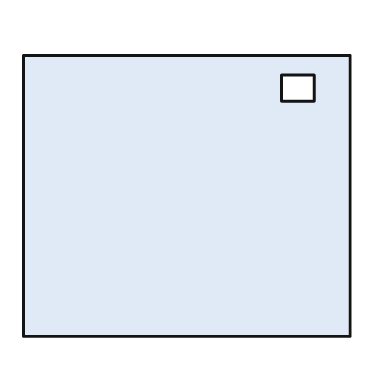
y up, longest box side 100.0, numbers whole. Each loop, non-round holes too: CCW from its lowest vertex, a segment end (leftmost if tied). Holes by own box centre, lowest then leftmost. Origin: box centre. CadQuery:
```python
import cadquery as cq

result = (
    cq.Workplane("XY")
    .moveTo(-50.0, -43.0)
    .lineTo(50.0, -43.0)
    .lineTo(50.0, 43.0)
    .lineTo(-50.0, 43.0)
    .close()
    .moveTo(29.0, 29.0)
    .lineTo(39.0, 29.0)
    .lineTo(39.0, 37.0)
    .lineTo(29.0, 37.0)
    .close()
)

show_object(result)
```